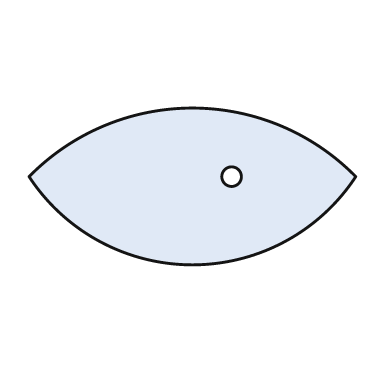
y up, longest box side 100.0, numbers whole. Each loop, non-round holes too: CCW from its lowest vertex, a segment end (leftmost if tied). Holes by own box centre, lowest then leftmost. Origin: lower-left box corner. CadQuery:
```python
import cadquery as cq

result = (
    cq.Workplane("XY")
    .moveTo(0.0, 27.0)
    .threePointArc((50.0, 0.0), (100.0, 27.0))
    .threePointArc((50.0, 48.0), (0.0, 27.0))
    .close()
    .moveTo(62.0, 27.0)
    .circle(3.0)
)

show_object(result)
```